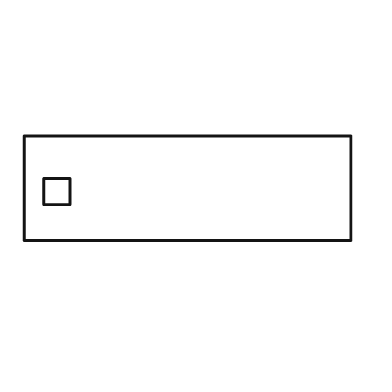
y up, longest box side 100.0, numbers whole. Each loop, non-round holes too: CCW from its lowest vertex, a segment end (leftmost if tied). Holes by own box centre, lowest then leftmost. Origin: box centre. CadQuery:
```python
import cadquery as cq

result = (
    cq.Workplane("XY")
    .moveTo(-50.0, -16.0)
    .lineTo(50.0, -16.0)
    .lineTo(50.0, 16.0)
    .lineTo(-50.0, 16.0)
    .close()
    .moveTo(-44.0, -5.0)
    .lineTo(-36.0, -5.0)
    .lineTo(-36.0, 3.0)
    .lineTo(-44.0, 3.0)
    .close()
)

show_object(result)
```